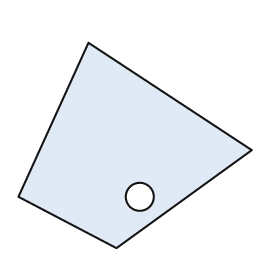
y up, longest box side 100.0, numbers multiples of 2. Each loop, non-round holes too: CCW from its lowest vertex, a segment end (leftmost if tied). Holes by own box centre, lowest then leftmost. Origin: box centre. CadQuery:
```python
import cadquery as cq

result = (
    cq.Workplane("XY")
    .moveTo(-8.0, -44.0)
    .lineTo(50.0, -2.0)
    .lineTo(-20.0, 44.0)
    .lineTo(-50.0, -22.0)
    .close()
    .moveTo(2.0, -22.0)
    .circle(6.0)
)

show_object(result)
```